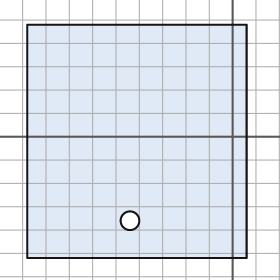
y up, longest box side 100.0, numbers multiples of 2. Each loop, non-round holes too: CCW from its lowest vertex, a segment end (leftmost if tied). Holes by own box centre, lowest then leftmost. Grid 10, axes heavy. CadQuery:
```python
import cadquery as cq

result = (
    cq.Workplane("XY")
    .moveTo(-88.0, -52.0)
    .lineTo(6.0, -52.0)
    .lineTo(6.0, 48.0)
    .lineTo(-88.0, 48.0)
    .close()
    .moveTo(-44.0, -36.0)
    .circle(4.0)
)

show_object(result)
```